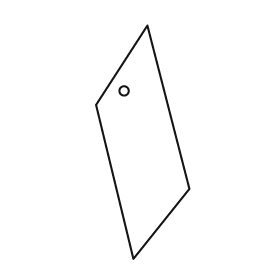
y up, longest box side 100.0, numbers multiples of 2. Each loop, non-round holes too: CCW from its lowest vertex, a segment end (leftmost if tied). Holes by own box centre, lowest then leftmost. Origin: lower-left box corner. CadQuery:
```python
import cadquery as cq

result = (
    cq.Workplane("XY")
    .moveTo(16.0, 0.0)
    .lineTo(40.0, 30.0)
    .lineTo(22.0, 100.0)
    .lineTo(0.0, 66.0)
    .close()
    .moveTo(12.0, 72.0)
    .circle(2.0)
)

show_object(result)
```